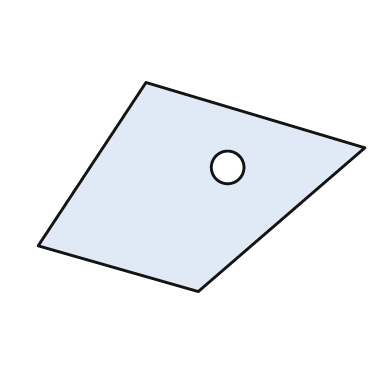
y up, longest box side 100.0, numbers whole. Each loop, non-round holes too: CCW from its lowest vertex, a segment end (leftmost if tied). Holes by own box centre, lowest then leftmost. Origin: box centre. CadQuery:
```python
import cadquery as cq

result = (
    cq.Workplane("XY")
    .moveTo(-1.0, -32.0)
    .lineTo(50.0, 12.0)
    .lineTo(-17.0, 32.0)
    .lineTo(-50.0, -18.0)
    .close()
    .moveTo(8.0, 6.0)
    .circle(5.0)
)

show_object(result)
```